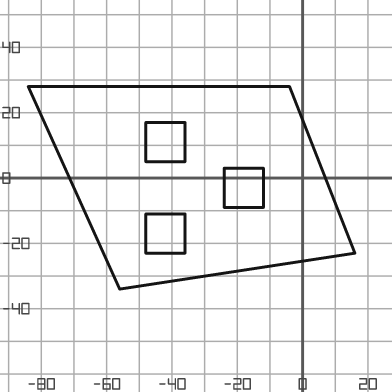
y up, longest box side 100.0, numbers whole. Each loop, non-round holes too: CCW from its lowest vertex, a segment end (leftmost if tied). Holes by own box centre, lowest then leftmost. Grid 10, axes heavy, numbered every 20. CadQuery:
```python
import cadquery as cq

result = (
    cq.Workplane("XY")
    .moveTo(-56.0, -34.0)
    .lineTo(16.0, -23.0)
    .lineTo(-4.0, 28.0)
    .lineTo(-84.0, 28.0)
    .close()
    .moveTo(-48.0, -23.0)
    .lineTo(-36.0, -23.0)
    .lineTo(-36.0, -11.0)
    .lineTo(-48.0, -11.0)
    .close()
    .moveTo(-24.0, -9.0)
    .lineTo(-12.0, -9.0)
    .lineTo(-12.0, 3.0)
    .lineTo(-24.0, 3.0)
    .close()
    .moveTo(-48.0, 5.0)
    .lineTo(-36.0, 5.0)
    .lineTo(-36.0, 17.0)
    .lineTo(-48.0, 17.0)
    .close()
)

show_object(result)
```